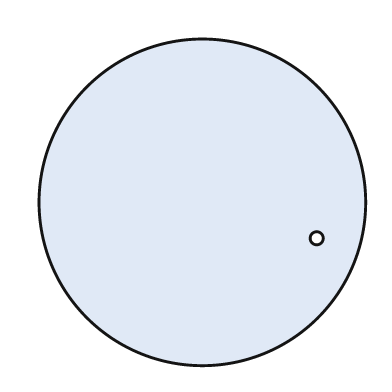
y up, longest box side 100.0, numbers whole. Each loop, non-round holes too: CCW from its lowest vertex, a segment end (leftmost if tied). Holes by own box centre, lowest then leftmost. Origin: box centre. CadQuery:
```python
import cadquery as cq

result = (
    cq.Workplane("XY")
    .moveTo(0.0, 0.0)
    .circle(50.0)
    .moveTo(35.0, -11.0)
    .circle(2.0)
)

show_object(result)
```